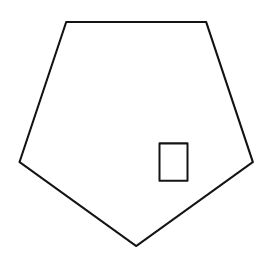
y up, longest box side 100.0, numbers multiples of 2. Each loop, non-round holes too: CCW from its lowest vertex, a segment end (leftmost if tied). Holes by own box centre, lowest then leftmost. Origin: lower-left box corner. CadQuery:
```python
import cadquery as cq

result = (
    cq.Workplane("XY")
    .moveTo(50.0, 0.0)
    .lineTo(100.0, 36.0)
    .lineTo(80.0, 96.0)
    .lineTo(20.0, 96.0)
    .lineTo(0.0, 36.0)
    .close()
    .moveTo(60.0, 28.0)
    .lineTo(72.0, 28.0)
    .lineTo(72.0, 44.0)
    .lineTo(60.0, 44.0)
    .close()
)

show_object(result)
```